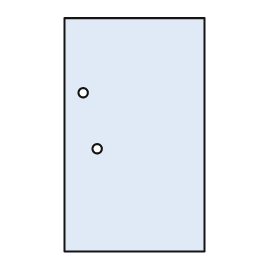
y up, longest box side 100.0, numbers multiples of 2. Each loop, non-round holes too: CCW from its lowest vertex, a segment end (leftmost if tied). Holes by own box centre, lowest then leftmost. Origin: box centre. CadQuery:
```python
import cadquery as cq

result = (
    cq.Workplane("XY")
    .moveTo(-30.0, -50.0)
    .lineTo(30.0, -50.0)
    .lineTo(30.0, 50.0)
    .lineTo(-30.0, 50.0)
    .close()
    .moveTo(-16.0, -6.0)
    .circle(2.0)
    .moveTo(-22.0, 18.0)
    .circle(2.0)
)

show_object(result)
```